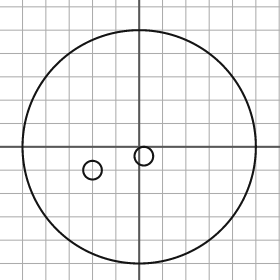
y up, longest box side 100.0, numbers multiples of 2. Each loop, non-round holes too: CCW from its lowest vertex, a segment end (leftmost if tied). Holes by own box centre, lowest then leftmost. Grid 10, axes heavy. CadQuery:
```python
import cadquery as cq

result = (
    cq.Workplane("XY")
    .moveTo(0.0, 0.0)
    .circle(50.0)
    .moveTo(-20.0, -10.0)
    .circle(4.0)
    .moveTo(2.0, -4.0)
    .circle(4.0)
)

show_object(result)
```